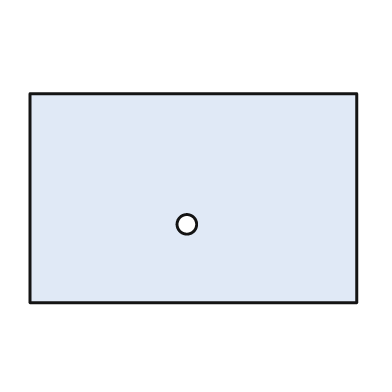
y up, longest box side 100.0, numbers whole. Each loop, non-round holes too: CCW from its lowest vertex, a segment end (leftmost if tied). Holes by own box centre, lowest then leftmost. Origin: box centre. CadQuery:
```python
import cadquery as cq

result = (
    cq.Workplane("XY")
    .moveTo(-50.0, -32.0)
    .lineTo(50.0, -32.0)
    .lineTo(50.0, 32.0)
    .lineTo(-50.0, 32.0)
    .close()
    .moveTo(-2.0, -8.0)
    .circle(3.0)
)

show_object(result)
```